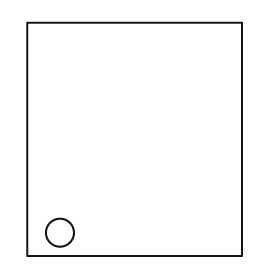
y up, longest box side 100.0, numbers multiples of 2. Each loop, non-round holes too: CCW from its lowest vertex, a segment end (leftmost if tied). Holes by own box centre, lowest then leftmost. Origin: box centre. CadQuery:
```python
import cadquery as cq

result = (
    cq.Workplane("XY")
    .moveTo(-46.0, -50.0)
    .lineTo(46.0, -50.0)
    .lineTo(46.0, 50.0)
    .lineTo(-46.0, 50.0)
    .close()
    .moveTo(-32.0, -40.0)
    .circle(6.0)
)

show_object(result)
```